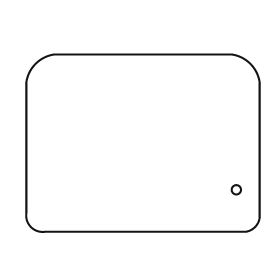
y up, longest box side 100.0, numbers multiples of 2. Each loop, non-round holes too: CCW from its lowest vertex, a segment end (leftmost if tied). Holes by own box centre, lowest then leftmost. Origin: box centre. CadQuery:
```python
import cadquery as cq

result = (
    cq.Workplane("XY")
    .moveTo(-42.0, -38.0)
    .lineTo(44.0, -38.0)
    .threePointArc((48.0, -36.0), (50.0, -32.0))
    .lineTo(50.0, 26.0)
    .threePointArc((46.0, 34.0), (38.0, 38.0))
    .lineTo(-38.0, 38.0)
    .threePointArc((-46.0, 34.0), (-50.0, 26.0))
    .lineTo(-50.0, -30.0)
    .threePointArc((-48.0, -36.0), (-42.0, -38.0))
    .close()
    .moveTo(40.0, -20.0)
    .circle(2.0)
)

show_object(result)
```